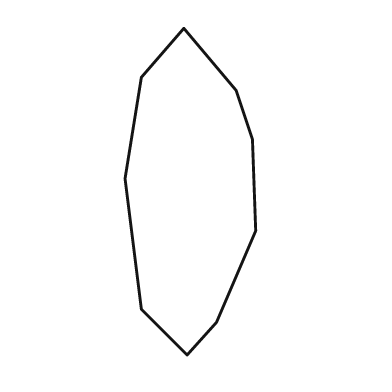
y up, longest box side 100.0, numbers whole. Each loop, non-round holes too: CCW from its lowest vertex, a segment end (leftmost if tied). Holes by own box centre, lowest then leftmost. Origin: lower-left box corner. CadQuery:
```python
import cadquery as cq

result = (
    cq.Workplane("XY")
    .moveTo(19.0, 0.0)
    .lineTo(28.0, 10.0)
    .lineTo(40.0, 38.0)
    .lineTo(39.0, 66.0)
    .lineTo(34.0, 81.0)
    .lineTo(18.0, 100.0)
    .lineTo(5.0, 85.0)
    .lineTo(0.0, 54.0)
    .lineTo(5.0, 14.0)
    .close()
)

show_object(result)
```